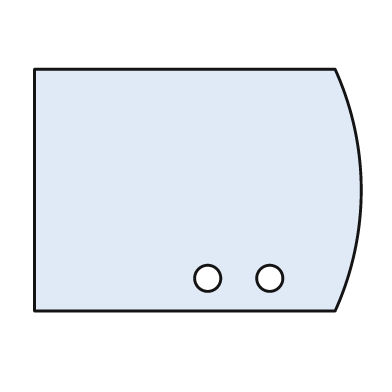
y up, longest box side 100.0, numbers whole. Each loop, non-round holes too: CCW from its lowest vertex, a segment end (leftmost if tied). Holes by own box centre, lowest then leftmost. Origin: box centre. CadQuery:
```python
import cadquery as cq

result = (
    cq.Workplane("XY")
    .moveTo(-50.0, -37.0)
    .lineTo(42.0, -37.0)
    .threePointArc((50.0, 0.0), (42.0, 37.0))
    .lineTo(-50.0, 37.0)
    .close()
    .moveTo(3.0, -27.0)
    .circle(4.0)
    .moveTo(22.0, -27.0)
    .circle(4.0)
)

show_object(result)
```